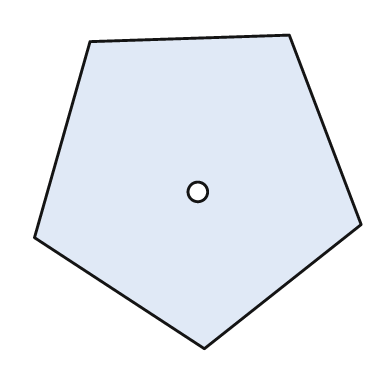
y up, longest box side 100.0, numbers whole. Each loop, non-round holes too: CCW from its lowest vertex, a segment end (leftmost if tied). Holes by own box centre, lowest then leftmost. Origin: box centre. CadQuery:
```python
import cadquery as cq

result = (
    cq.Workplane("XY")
    .moveTo(2.0, -48.0)
    .lineTo(50.0, -10.0)
    .lineTo(28.0, 48.0)
    .lineTo(-33.0, 46.0)
    .lineTo(-50.0, -14.0)
    .close()
    .moveTo(0.0, 0.0)
    .circle(3.0)
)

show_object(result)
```